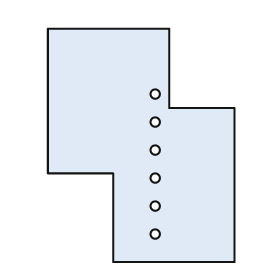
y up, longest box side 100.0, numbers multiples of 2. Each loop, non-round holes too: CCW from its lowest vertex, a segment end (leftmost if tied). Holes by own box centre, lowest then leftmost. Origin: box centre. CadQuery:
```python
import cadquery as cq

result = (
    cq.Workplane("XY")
    .moveTo(-12.0, -50.0)
    .lineTo(40.0, -50.0)
    .lineTo(40.0, 16.0)
    .lineTo(12.0, 16.0)
    .lineTo(12.0, 50.0)
    .lineTo(-40.0, 50.0)
    .lineTo(-40.0, -12.0)
    .lineTo(-12.0, -12.0)
    .close()
    .moveTo(6.0, -38.0)
    .circle(2.0)
    .moveTo(6.0, -26.0)
    .circle(2.0)
    .moveTo(6.0, -14.0)
    .circle(2.0)
    .moveTo(6.0, -2.0)
    .circle(2.0)
    .moveTo(6.0, 10.0)
    .circle(2.0)
    .moveTo(6.0, 22.0)
    .circle(2.0)
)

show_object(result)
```